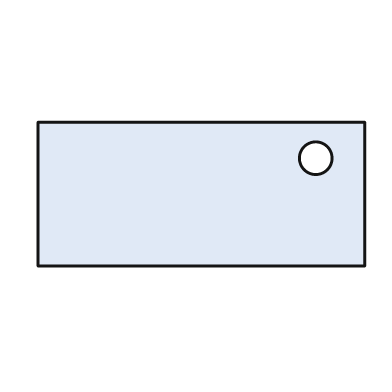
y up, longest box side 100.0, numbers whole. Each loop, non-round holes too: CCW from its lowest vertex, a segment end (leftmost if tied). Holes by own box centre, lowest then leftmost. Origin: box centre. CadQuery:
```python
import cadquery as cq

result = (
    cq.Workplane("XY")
    .moveTo(-50.0, -22.0)
    .lineTo(50.0, -22.0)
    .lineTo(50.0, 22.0)
    .lineTo(-50.0, 22.0)
    .close()
    .moveTo(35.0, 11.0)
    .circle(5.0)
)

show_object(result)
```